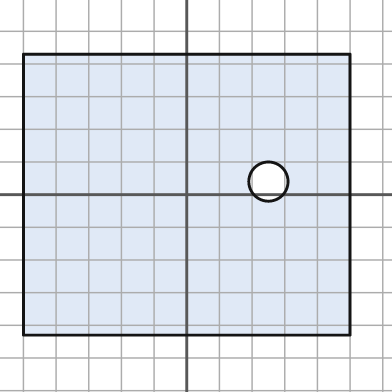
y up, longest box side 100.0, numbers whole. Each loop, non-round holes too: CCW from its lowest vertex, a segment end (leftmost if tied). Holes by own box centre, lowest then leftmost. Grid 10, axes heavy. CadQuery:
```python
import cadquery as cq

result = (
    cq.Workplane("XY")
    .moveTo(-50.0, -43.0)
    .lineTo(50.0, -43.0)
    .lineTo(50.0, 43.0)
    .lineTo(-50.0, 43.0)
    .close()
    .moveTo(25.0, 4.0)
    .circle(6.0)
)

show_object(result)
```